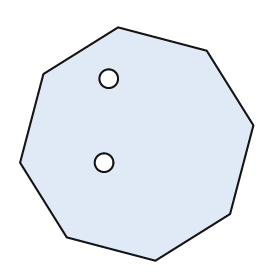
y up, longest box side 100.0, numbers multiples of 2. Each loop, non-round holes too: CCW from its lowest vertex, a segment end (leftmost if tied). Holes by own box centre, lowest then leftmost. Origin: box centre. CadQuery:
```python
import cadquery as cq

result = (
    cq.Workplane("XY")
    .moveTo(8.0, -50.0)
    .lineTo(40.0, -30.0)
    .lineTo(50.0, 8.0)
    .lineTo(30.0, 40.0)
    .lineTo(-8.0, 50.0)
    .lineTo(-40.0, 30.0)
    .lineTo(-50.0, -8.0)
    .lineTo(-30.0, -40.0)
    .close()
    .moveTo(-14.0, -8.0)
    .circle(4.0)
    .moveTo(-12.0, 28.0)
    .circle(4.0)
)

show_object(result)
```